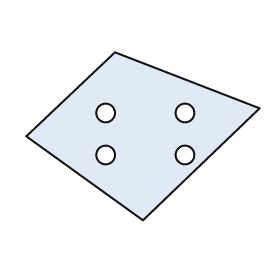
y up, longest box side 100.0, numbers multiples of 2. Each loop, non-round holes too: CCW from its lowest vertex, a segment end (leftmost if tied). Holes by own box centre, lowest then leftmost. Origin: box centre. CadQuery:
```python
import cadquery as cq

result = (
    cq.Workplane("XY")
    .moveTo(0.0, -36.0)
    .lineTo(50.0, 12.0)
    .lineTo(-12.0, 36.0)
    .lineTo(-50.0, 0.0)
    .close()
    .moveTo(-16.0, -8.0)
    .circle(4.0)
    .moveTo(18.0, -8.0)
    .circle(4.0)
    .moveTo(-16.0, 10.0)
    .circle(4.0)
    .moveTo(18.0, 10.0)
    .circle(4.0)
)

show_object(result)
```